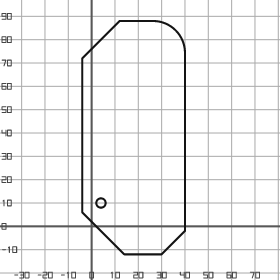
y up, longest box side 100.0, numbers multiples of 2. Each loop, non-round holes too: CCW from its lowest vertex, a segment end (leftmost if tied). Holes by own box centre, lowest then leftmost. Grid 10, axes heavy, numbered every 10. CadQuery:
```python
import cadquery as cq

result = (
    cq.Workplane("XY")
    .moveTo(14.0, -12.0)
    .lineTo(30.0, -12.0)
    .lineTo(40.0, -2.0)
    .lineTo(40.0, 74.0)
    .threePointArc((36.0, 84.0), (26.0, 88.0))
    .lineTo(12.0, 88.0)
    .lineTo(-4.0, 72.0)
    .lineTo(-4.0, 6.0)
    .close()
    .moveTo(4.0, 10.0)
    .circle(2.0)
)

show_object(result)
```